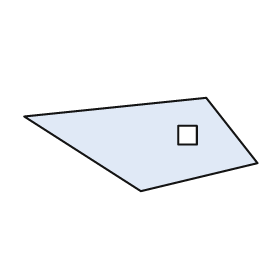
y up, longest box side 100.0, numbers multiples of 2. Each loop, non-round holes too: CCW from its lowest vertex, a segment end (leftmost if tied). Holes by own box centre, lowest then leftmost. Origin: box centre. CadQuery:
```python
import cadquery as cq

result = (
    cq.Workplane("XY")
    .moveTo(0.0, -20.0)
    .lineTo(50.0, -8.0)
    .lineTo(28.0, 20.0)
    .lineTo(-50.0, 12.0)
    .close()
    .moveTo(16.0, 0.0)
    .lineTo(24.0, 0.0)
    .lineTo(24.0, 8.0)
    .lineTo(16.0, 8.0)
    .close()
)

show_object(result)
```